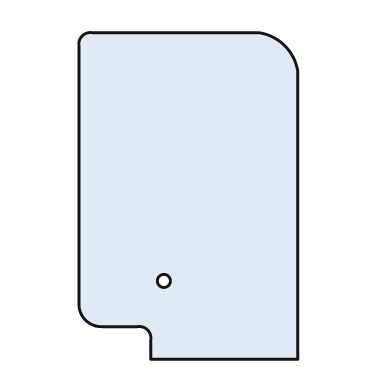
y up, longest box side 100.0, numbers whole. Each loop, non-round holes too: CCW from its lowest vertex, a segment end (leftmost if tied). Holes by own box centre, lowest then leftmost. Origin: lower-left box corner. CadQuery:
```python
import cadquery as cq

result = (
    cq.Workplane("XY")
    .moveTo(22.0, 0.0)
    .lineTo(67.0, 0.0)
    .lineTo(67.0, 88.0)
    .threePointArc((63.0, 96.0), (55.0, 100.0))
    .lineTo(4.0, 100.0)
    .threePointArc((1.0, 99.0), (0.0, 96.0))
    .lineTo(0.0, 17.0)
    .threePointArc((2.0, 12.0), (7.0, 10.0))
    .lineTo(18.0, 10.0)
    .threePointArc((21.0, 9.0), (22.0, 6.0))
    .close()
    .moveTo(26.0, 24.0)
    .circle(2.0)
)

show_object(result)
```